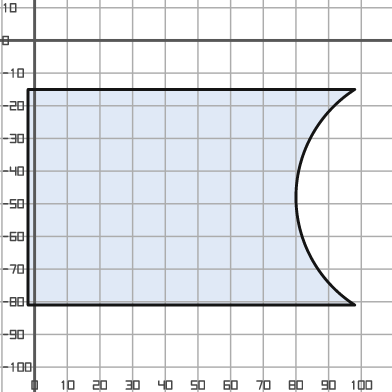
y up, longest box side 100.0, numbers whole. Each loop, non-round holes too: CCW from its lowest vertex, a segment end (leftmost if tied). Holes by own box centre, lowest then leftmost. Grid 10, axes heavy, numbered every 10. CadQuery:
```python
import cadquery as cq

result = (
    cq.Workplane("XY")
    .moveTo(-2.0, -81.0)
    .lineTo(98.0, -81.0)
    .threePointArc((80.0, -48.0), (98.0, -15.0))
    .lineTo(-2.0, -15.0)
    .close()
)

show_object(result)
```